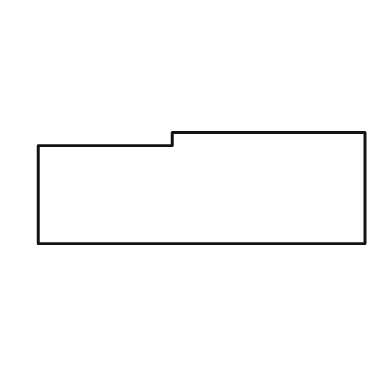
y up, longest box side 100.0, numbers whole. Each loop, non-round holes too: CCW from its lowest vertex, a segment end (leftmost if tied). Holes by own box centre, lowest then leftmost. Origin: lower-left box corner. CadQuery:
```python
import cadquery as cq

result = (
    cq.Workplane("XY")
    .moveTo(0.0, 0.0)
    .lineTo(100.0, 0.0)
    .lineTo(100.0, 34.0)
    .lineTo(41.0, 34.0)
    .lineTo(41.0, 30.0)
    .lineTo(0.0, 30.0)
    .close()
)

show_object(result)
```